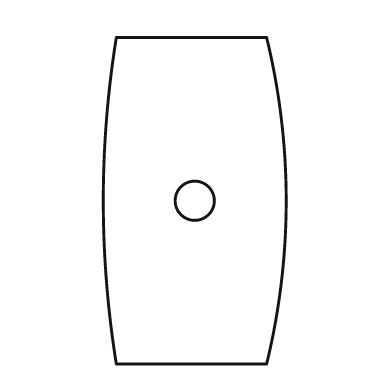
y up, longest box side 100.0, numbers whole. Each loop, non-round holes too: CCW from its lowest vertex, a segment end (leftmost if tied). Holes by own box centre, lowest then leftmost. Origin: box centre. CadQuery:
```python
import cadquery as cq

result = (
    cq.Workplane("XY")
    .moveTo(-24.0, -50.0)
    .lineTo(22.0, -50.0)
    .threePointArc((28.0, 0.0), (22.0, 50.0))
    .lineTo(-24.0, 50.0)
    .threePointArc((-28.0, 0.0), (-24.0, -50.0))
    .close()
    .moveTo(0.0, 0.0)
    .circle(6.0)
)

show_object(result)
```